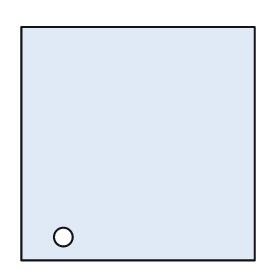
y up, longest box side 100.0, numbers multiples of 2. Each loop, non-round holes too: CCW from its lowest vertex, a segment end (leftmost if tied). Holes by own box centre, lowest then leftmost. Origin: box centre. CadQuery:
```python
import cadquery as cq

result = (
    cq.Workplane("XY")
    .moveTo(-50.0, -50.0)
    .lineTo(50.0, -50.0)
    .lineTo(50.0, 50.0)
    .lineTo(-50.0, 50.0)
    .close()
    .moveTo(-32.0, -40.0)
    .circle(4.0)
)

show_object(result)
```